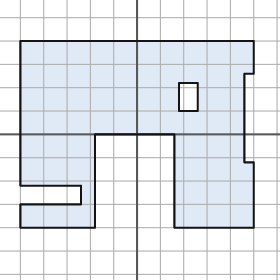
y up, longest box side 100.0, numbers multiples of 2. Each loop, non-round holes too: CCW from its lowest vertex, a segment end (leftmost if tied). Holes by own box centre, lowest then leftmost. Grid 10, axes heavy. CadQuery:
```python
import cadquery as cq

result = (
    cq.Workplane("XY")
    .moveTo(-50.0, -40.0)
    .lineTo(-18.0, -40.0)
    .lineTo(-18.0, 0.0)
    .lineTo(16.0, 0.0)
    .lineTo(16.0, -40.0)
    .lineTo(50.0, -40.0)
    .lineTo(50.0, -12.0)
    .lineTo(46.0, -12.0)
    .lineTo(46.0, 26.0)
    .lineTo(50.0, 26.0)
    .lineTo(50.0, 40.0)
    .lineTo(-50.0, 40.0)
    .lineTo(-50.0, -22.0)
    .lineTo(-24.0, -22.0)
    .lineTo(-24.0, -30.0)
    .lineTo(-50.0, -30.0)
    .close()
    .moveTo(18.0, 10.0)
    .lineTo(26.0, 10.0)
    .lineTo(26.0, 22.0)
    .lineTo(18.0, 22.0)
    .close()
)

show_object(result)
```